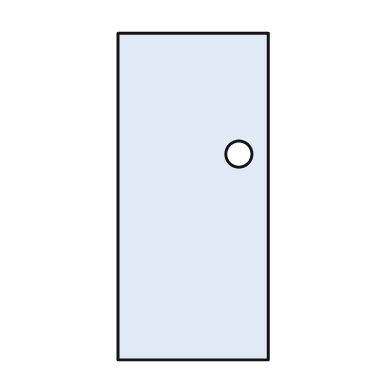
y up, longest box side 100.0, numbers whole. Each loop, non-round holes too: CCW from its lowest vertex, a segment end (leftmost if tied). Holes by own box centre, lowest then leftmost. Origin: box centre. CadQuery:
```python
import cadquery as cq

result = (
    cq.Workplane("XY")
    .moveTo(-23.0, -50.0)
    .lineTo(23.0, -50.0)
    .lineTo(23.0, 50.0)
    .lineTo(-23.0, 50.0)
    .close()
    .moveTo(14.0, 13.0)
    .circle(4.0)
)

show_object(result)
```